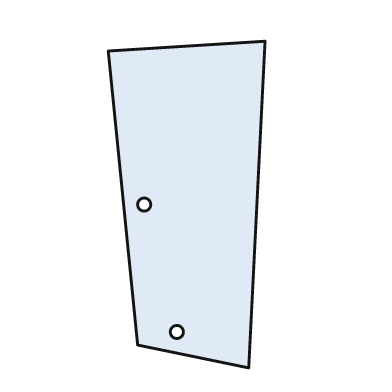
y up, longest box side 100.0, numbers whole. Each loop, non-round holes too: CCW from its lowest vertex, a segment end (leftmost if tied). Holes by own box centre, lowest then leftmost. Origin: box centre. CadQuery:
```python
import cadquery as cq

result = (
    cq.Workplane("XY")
    .moveTo(19.0, -50.0)
    .lineTo(24.0, 50.0)
    .lineTo(-24.0, 47.0)
    .lineTo(-15.0, -43.0)
    .close()
    .moveTo(-3.0, -39.0)
    .circle(2.0)
    .moveTo(-13.0, 0.0)
    .circle(2.0)
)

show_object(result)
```